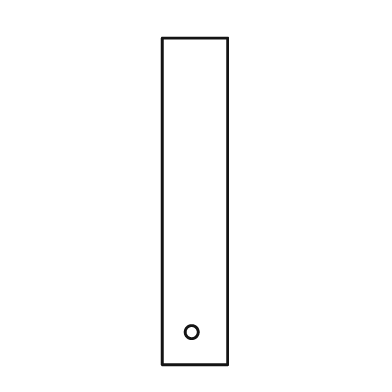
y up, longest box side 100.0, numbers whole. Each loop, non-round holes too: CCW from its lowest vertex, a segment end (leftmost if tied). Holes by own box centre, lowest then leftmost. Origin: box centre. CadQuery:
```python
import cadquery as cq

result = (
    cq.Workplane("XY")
    .moveTo(-10.0, -50.0)
    .lineTo(10.0, -50.0)
    .lineTo(10.0, 50.0)
    .lineTo(-10.0, 50.0)
    .close()
    .moveTo(-1.0, -40.0)
    .circle(2.0)
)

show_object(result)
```